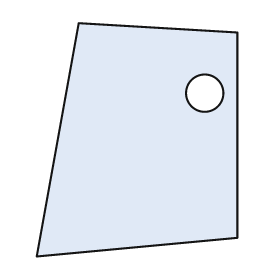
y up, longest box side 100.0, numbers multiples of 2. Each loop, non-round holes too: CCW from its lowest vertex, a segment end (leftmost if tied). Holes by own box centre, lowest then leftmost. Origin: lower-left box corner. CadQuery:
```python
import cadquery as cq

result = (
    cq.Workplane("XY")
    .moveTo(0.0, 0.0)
    .lineTo(86.0, 8.0)
    .lineTo(86.0, 96.0)
    .lineTo(18.0, 100.0)
    .close()
    .moveTo(72.0, 70.0)
    .circle(8.0)
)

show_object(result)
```